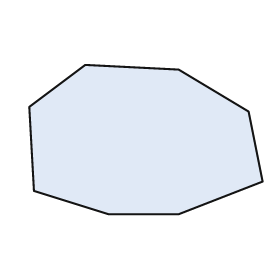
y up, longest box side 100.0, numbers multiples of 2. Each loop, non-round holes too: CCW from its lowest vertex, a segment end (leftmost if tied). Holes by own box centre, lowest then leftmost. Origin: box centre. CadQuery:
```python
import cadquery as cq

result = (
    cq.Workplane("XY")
    .moveTo(-16.0, -32.0)
    .lineTo(14.0, -32.0)
    .lineTo(50.0, -18.0)
    .lineTo(44.0, 12.0)
    .lineTo(14.0, 30.0)
    .lineTo(-26.0, 32.0)
    .lineTo(-50.0, 14.0)
    .lineTo(-48.0, -22.0)
    .close()
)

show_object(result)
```